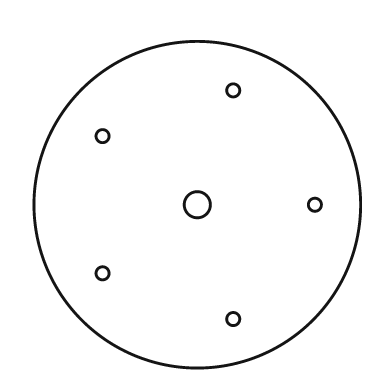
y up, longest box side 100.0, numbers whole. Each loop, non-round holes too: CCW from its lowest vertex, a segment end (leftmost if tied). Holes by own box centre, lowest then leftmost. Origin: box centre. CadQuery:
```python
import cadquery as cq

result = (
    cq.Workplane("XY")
    .moveTo(0.0, 0.0)
    .circle(50.0)
    .moveTo(11.0, -35.0)
    .circle(2.0)
    .moveTo(-29.0, -21.0)
    .circle(2.0)
    .moveTo(0.0, 0.0)
    .circle(4.0)
    .moveTo(36.0, 0.0)
    .circle(2.0)
    .moveTo(-29.0, 21.0)
    .circle(2.0)
    .moveTo(11.0, 35.0)
    .circle(2.0)
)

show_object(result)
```